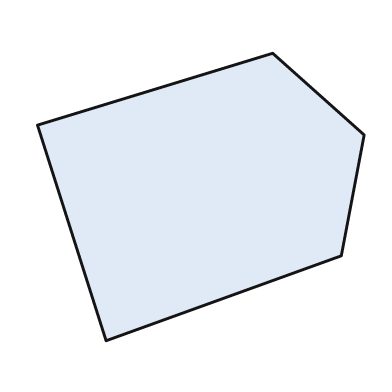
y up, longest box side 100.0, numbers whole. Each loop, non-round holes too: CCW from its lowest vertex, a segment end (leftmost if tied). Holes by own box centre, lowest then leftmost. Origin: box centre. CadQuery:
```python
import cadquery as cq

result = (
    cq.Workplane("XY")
    .moveTo(-29.0, -44.0)
    .lineTo(43.0, -18.0)
    .lineTo(50.0, 19.0)
    .lineTo(22.0, 44.0)
    .lineTo(-50.0, 22.0)
    .close()
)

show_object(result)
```